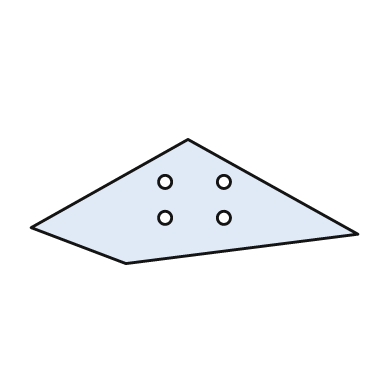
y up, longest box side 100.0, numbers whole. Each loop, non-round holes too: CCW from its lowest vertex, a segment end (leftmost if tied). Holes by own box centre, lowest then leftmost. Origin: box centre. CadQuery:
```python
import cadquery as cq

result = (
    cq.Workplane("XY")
    .moveTo(-21.0, -19.0)
    .lineTo(50.0, -10.0)
    .lineTo(-2.0, 19.0)
    .lineTo(-50.0, -8.0)
    .close()
    .moveTo(-9.0, -5.0)
    .circle(2.0)
    .moveTo(9.0, -5.0)
    .circle(2.0)
    .moveTo(-9.0, 6.0)
    .circle(2.0)
    .moveTo(9.0, 6.0)
    .circle(2.0)
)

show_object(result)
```